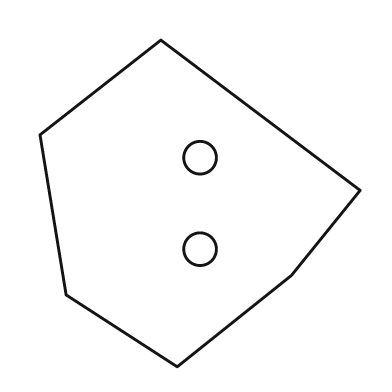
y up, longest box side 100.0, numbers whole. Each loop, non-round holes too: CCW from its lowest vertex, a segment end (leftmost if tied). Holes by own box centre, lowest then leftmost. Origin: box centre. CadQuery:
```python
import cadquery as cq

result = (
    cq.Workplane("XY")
    .moveTo(-7.0, -50.0)
    .lineTo(28.0, -22.0)
    .lineTo(49.0, 4.0)
    .lineTo(-12.0, 50.0)
    .lineTo(-49.0, 21.0)
    .lineTo(-41.0, -28.0)
    .close()
    .moveTo(0.0, -14.0)
    .circle(5.0)
    .moveTo(0.0, 14.0)
    .circle(5.0)
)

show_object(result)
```